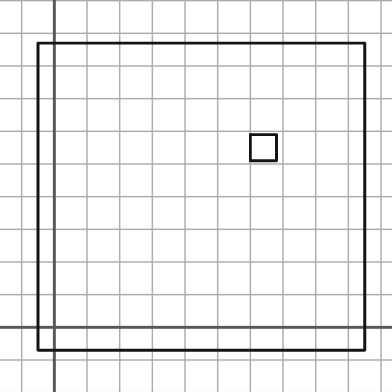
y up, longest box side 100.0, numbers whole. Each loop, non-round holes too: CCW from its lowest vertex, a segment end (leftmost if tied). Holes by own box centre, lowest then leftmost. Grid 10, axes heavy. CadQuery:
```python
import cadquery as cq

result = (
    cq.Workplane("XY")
    .moveTo(-5.0, -7.0)
    .lineTo(95.0, -7.0)
    .lineTo(95.0, 87.0)
    .lineTo(-5.0, 87.0)
    .close()
    .moveTo(60.0, 51.0)
    .lineTo(68.0, 51.0)
    .lineTo(68.0, 59.0)
    .lineTo(60.0, 59.0)
    .close()
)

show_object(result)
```